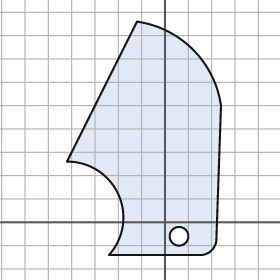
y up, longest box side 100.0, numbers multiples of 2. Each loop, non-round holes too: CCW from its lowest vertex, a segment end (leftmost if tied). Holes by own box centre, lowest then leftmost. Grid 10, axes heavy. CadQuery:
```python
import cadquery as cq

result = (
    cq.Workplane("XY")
    .moveTo(-24.0, -14.0)
    .lineTo(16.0, -14.0)
    .threePointArc((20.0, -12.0), (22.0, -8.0))
    .lineTo(24.0, 50.0)
    .threePointArc((12.0, 74.0), (-12.0, 86.0))
    .lineTo(-42.0, 26.0)
    .threePointArc((-20.0, 12.0), (-24.0, -14.0))
    .close()
    .moveTo(6.0, -6.0)
    .circle(4.0)
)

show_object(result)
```